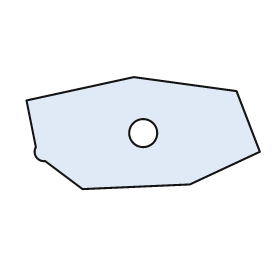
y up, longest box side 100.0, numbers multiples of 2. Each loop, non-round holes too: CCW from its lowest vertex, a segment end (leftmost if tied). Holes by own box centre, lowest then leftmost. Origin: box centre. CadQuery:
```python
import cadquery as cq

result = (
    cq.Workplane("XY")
    .moveTo(-26.0, -24.0)
    .lineTo(20.0, -22.0)
    .lineTo(50.0, -8.0)
    .lineTo(40.0, 18.0)
    .lineTo(-4.0, 24.0)
    .lineTo(-50.0, 14.0)
    .lineTo(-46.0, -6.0)
    .threePointArc((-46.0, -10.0), (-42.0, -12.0))
    .close()
    .moveTo(0.0, 0.0)
    .circle(6.0)
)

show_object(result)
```